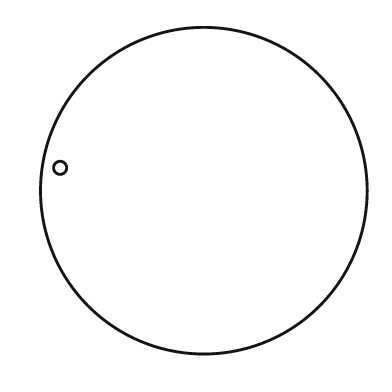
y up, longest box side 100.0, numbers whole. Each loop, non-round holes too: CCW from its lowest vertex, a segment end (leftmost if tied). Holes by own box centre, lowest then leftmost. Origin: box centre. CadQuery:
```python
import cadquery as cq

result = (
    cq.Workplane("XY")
    .moveTo(0.0, 0.0)
    .circle(50.0)
    .moveTo(-44.0, 7.0)
    .circle(2.0)
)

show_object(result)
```